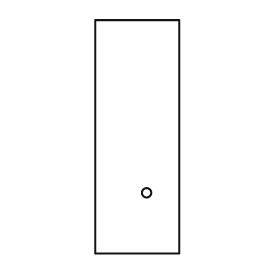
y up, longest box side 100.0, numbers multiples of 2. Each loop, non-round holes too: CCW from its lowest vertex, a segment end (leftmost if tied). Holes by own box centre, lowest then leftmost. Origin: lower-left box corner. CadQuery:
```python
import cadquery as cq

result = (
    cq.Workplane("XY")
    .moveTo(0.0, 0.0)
    .lineTo(36.0, 0.0)
    .lineTo(36.0, 100.0)
    .lineTo(0.0, 100.0)
    .close()
    .moveTo(22.0, 26.0)
    .circle(2.0)
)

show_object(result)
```